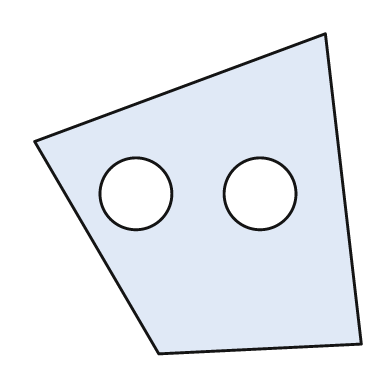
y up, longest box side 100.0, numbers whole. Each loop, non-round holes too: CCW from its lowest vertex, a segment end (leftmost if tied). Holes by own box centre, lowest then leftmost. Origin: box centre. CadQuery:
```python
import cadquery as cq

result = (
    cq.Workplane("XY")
    .moveTo(-12.0, -49.0)
    .lineTo(50.0, -46.0)
    .lineTo(39.0, 49.0)
    .lineTo(-50.0, 16.0)
    .close()
    .moveTo(-19.0, 0.0)
    .circle(11.0)
    .moveTo(19.0, 0.0)
    .circle(11.0)
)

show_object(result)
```